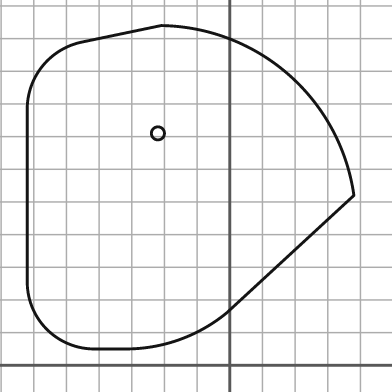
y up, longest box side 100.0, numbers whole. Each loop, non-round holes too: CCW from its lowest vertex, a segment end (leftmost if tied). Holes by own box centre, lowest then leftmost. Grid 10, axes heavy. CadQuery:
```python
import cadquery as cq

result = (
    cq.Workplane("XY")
    .moveTo(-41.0, 5.0)
    .lineTo(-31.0, 5.0)
    .threePointArc((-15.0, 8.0), (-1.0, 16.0))
    .lineTo(38.0, 52.0)
    .threePointArc((18.0, 89.0), (-21.0, 104.0))
    .lineTo(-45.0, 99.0)
    .threePointArc((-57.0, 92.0), (-62.0, 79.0))
    .lineTo(-62.0, 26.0)
    .threePointArc((-56.0, 11.0), (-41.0, 5.0))
    .close()
    .moveTo(-22.0, 71.0)
    .circle(2.0)
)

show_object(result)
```